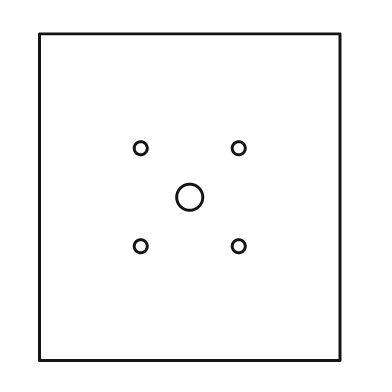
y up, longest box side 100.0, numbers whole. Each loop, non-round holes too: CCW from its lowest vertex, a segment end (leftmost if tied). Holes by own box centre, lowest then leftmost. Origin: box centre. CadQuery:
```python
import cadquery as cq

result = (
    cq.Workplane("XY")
    .moveTo(-46.0, -50.0)
    .lineTo(46.0, -50.0)
    .lineTo(46.0, 50.0)
    .lineTo(-46.0, 50.0)
    .close()
    .moveTo(-15.0, -15.0)
    .circle(2.0)
    .moveTo(15.0, -15.0)
    .circle(2.0)
    .moveTo(0.0, 0.0)
    .circle(4.0)
    .moveTo(-15.0, 15.0)
    .circle(2.0)
    .moveTo(15.0, 15.0)
    .circle(2.0)
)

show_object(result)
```